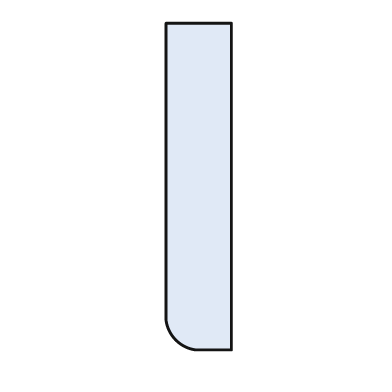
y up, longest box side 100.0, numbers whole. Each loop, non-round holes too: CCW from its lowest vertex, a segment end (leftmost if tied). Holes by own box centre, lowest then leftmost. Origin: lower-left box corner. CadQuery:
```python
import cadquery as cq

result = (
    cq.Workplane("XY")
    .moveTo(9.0, 0.0)
    .lineTo(20.0, 0.0)
    .lineTo(20.0, 100.0)
    .lineTo(0.0, 100.0)
    .lineTo(0.0, 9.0)
    .threePointArc((3.0, 3.0), (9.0, 0.0))
    .close()
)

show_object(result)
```